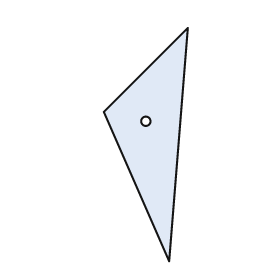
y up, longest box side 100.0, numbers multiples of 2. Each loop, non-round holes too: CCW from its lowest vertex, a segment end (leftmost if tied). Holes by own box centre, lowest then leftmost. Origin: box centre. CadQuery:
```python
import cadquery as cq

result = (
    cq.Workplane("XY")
    .moveTo(10.0, -50.0)
    .lineTo(18.0, 50.0)
    .lineTo(-18.0, 14.0)
    .close()
    .moveTo(0.0, 10.0)
    .circle(2.0)
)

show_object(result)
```